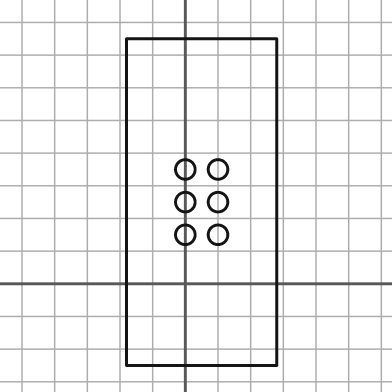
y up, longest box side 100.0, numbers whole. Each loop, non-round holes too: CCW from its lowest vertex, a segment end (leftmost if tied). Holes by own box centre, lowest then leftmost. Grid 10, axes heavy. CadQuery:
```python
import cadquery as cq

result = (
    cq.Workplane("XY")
    .moveTo(-18.0, -25.0)
    .lineTo(28.0, -25.0)
    .lineTo(28.0, 75.0)
    .lineTo(-18.0, 75.0)
    .close()
    .moveTo(0.0, 15.0)
    .circle(3.0)
    .moveTo(10.0, 15.0)
    .circle(3.0)
    .moveTo(0.0, 25.0)
    .circle(3.0)
    .moveTo(10.0, 25.0)
    .circle(3.0)
    .moveTo(0.0, 35.0)
    .circle(3.0)
    .moveTo(10.0, 35.0)
    .circle(3.0)
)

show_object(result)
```